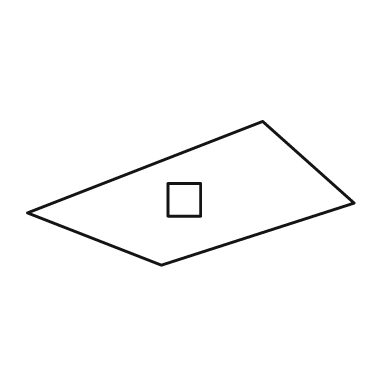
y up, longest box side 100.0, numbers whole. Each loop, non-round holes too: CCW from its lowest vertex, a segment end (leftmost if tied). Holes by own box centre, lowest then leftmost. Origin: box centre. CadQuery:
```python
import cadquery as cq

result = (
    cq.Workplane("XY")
    .moveTo(-9.0, -22.0)
    .lineTo(50.0, -3.0)
    .lineTo(22.0, 22.0)
    .lineTo(-50.0, -6.0)
    .close()
    .moveTo(-7.0, -7.0)
    .lineTo(3.0, -7.0)
    .lineTo(3.0, 3.0)
    .lineTo(-7.0, 3.0)
    .close()
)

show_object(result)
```